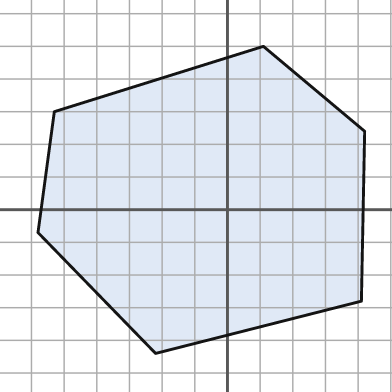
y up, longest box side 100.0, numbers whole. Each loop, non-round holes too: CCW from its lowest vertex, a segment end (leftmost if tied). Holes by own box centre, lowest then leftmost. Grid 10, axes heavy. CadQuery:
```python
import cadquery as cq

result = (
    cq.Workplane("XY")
    .moveTo(-22.0, -44.0)
    .lineTo(41.0, -28.0)
    .lineTo(42.0, 24.0)
    .lineTo(11.0, 50.0)
    .lineTo(-53.0, 30.0)
    .lineTo(-58.0, -7.0)
    .close()
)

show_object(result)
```